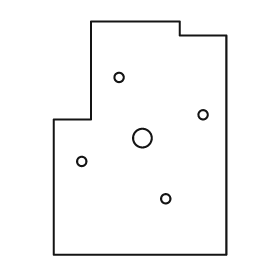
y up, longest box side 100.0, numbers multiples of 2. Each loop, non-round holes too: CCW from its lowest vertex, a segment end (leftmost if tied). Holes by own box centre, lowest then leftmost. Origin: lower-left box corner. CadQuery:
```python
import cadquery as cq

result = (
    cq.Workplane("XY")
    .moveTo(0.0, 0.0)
    .lineTo(74.0, 0.0)
    .lineTo(74.0, 94.0)
    .lineTo(54.0, 94.0)
    .lineTo(54.0, 100.0)
    .lineTo(16.0, 100.0)
    .lineTo(16.0, 58.0)
    .lineTo(0.0, 58.0)
    .close()
    .moveTo(48.0, 24.0)
    .circle(2.0)
    .moveTo(12.0, 40.0)
    .circle(2.0)
    .moveTo(38.0, 50.0)
    .circle(4.0)
    .moveTo(64.0, 60.0)
    .circle(2.0)
    .moveTo(28.0, 76.0)
    .circle(2.0)
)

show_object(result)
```